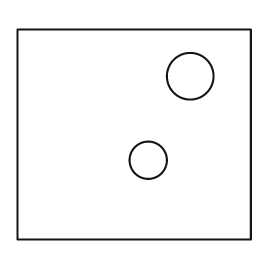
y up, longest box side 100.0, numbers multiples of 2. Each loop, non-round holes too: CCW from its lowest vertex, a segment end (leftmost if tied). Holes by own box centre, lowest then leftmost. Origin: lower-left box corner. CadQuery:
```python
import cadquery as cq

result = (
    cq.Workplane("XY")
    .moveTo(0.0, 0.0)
    .lineTo(100.0, 0.0)
    .lineTo(100.0, 90.0)
    .lineTo(0.0, 90.0)
    .close()
    .moveTo(56.0, 34.0)
    .circle(8.0)
    .moveTo(74.0, 70.0)
    .circle(10.0)
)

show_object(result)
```